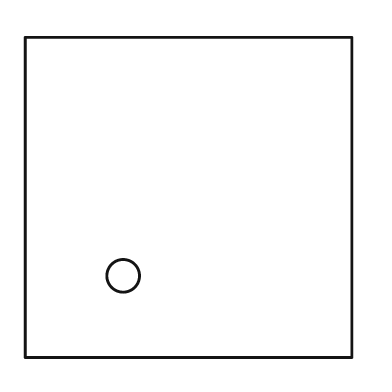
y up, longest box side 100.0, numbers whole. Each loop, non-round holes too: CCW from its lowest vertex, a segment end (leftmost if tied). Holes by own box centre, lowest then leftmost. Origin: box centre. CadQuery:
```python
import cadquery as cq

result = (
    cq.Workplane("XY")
    .moveTo(-50.0, -49.0)
    .lineTo(50.0, -49.0)
    .lineTo(50.0, 49.0)
    .lineTo(-50.0, 49.0)
    .close()
    .moveTo(-20.0, -24.0)
    .circle(5.0)
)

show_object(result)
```